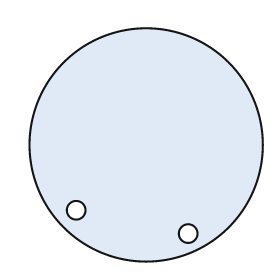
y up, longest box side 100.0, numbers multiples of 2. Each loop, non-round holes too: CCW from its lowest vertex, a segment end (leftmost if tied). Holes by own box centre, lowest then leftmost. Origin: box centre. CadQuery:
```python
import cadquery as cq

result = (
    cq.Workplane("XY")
    .moveTo(0.0, 0.0)
    .circle(50.0)
    .moveTo(18.0, -38.0)
    .circle(4.0)
    .moveTo(-30.0, -28.0)
    .circle(4.0)
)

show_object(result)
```